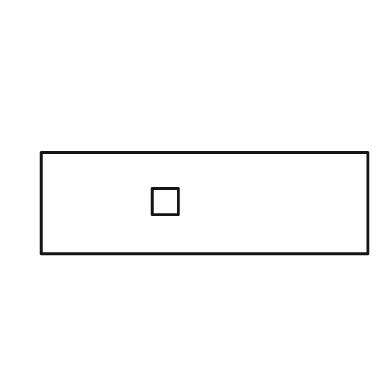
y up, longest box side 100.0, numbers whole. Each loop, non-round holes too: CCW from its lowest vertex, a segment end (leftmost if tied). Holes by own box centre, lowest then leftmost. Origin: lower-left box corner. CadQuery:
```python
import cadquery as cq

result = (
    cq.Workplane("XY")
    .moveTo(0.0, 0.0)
    .lineTo(100.0, 0.0)
    .lineTo(100.0, 31.0)
    .lineTo(0.0, 31.0)
    .close()
    .moveTo(34.0, 12.0)
    .lineTo(42.0, 12.0)
    .lineTo(42.0, 20.0)
    .lineTo(34.0, 20.0)
    .close()
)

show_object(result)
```